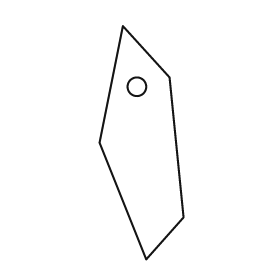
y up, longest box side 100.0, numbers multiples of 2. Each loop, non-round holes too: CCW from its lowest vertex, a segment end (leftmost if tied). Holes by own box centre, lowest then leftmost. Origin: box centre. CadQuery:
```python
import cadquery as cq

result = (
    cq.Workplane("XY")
    .moveTo(2.0, -50.0)
    .lineTo(18.0, -32.0)
    .lineTo(12.0, 28.0)
    .lineTo(-8.0, 50.0)
    .lineTo(-18.0, 0.0)
    .close()
    .moveTo(-2.0, 24.0)
    .circle(4.0)
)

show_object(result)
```